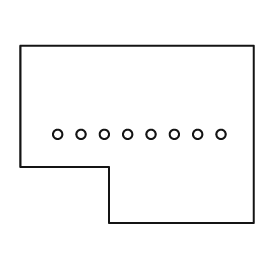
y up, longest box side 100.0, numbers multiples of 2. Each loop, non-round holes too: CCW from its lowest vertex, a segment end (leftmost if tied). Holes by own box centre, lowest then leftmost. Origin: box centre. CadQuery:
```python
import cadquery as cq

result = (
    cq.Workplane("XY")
    .moveTo(-12.0, -38.0)
    .lineTo(50.0, -38.0)
    .lineTo(50.0, 38.0)
    .lineTo(-50.0, 38.0)
    .lineTo(-50.0, -14.0)
    .lineTo(-12.0, -14.0)
    .close()
    .moveTo(-34.0, 0.0)
    .circle(2.0)
    .moveTo(-24.0, 0.0)
    .circle(2.0)
    .moveTo(-14.0, 0.0)
    .circle(2.0)
    .moveTo(-4.0, 0.0)
    .circle(2.0)
    .moveTo(6.0, 0.0)
    .circle(2.0)
    .moveTo(16.0, 0.0)
    .circle(2.0)
    .moveTo(26.0, 0.0)
    .circle(2.0)
    .moveTo(36.0, 0.0)
    .circle(2.0)
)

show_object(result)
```